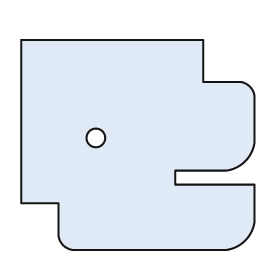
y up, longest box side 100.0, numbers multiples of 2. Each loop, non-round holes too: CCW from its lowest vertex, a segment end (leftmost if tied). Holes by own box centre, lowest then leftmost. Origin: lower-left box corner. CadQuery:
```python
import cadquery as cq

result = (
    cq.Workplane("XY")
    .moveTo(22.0, 0.0)
    .lineTo(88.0, 0.0)
    .threePointArc((96.0, 4.0), (100.0, 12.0))
    .lineTo(100.0, 28.0)
    .lineTo(66.0, 28.0)
    .lineTo(66.0, 34.0)
    .lineTo(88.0, 34.0)
    .threePointArc((96.0, 38.0), (100.0, 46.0))
    .lineTo(100.0, 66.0)
    .threePointArc((98.0, 70.0), (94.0, 72.0))
    .lineTo(78.0, 72.0)
    .lineTo(78.0, 90.0)
    .lineTo(0.0, 90.0)
    .lineTo(0.0, 20.0)
    .lineTo(16.0, 20.0)
    .lineTo(16.0, 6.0)
    .threePointArc((18.0, 2.0), (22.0, 0.0))
    .close()
    .moveTo(32.0, 48.0)
    .circle(4.0)
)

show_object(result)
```